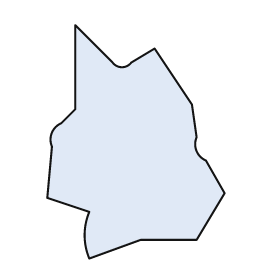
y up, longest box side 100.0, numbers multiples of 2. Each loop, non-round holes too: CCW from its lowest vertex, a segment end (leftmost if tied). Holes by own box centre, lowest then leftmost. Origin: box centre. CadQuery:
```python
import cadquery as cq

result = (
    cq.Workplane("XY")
    .moveTo(-20.0, -50.0)
    .lineTo(2.0, -42.0)
    .lineTo(26.0, -42.0)
    .lineTo(38.0, -22.0)
    .lineTo(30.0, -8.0)
    .threePointArc((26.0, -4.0), (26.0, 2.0))
    .lineTo(24.0, 16.0)
    .lineTo(8.0, 40.0)
    .lineTo(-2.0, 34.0)
    .threePointArc((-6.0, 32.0), (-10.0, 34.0))
    .lineTo(-26.0, 50.0)
    .lineTo(-26.0, 14.0)
    .lineTo(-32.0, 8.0)
    .threePointArc((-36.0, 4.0), (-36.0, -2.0))
    .lineTo(-38.0, -24.0)
    .lineTo(-20.0, -30.0)
    .threePointArc((-22.0, -40.0), (-20.0, -50.0))
    .close()
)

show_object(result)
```